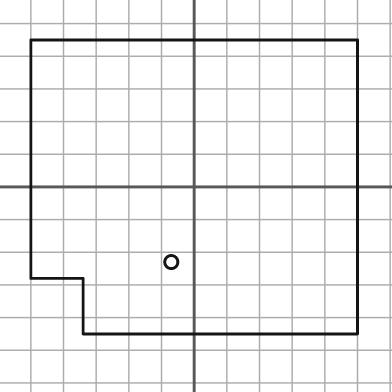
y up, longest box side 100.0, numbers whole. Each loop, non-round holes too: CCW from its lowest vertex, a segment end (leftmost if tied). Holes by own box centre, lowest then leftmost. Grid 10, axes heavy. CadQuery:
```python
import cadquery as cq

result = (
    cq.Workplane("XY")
    .moveTo(-34.0, -45.0)
    .lineTo(50.0, -45.0)
    .lineTo(50.0, 45.0)
    .lineTo(-50.0, 45.0)
    .lineTo(-50.0, -28.0)
    .lineTo(-34.0, -28.0)
    .close()
    .moveTo(-7.0, -23.0)
    .circle(2.0)
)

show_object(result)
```